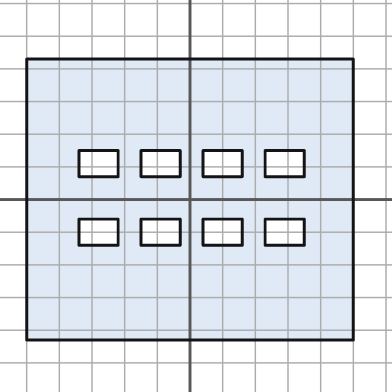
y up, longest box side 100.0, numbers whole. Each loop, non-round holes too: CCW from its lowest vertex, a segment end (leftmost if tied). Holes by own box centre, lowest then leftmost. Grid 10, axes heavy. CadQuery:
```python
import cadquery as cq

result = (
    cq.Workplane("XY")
    .moveTo(-50.0, -43.0)
    .lineTo(50.0, -43.0)
    .lineTo(50.0, 43.0)
    .lineTo(-50.0, 43.0)
    .close()
    .moveTo(-34.0, -14.0)
    .lineTo(-22.0, -14.0)
    .lineTo(-22.0, -6.0)
    .lineTo(-34.0, -6.0)
    .close()
    .moveTo(-15.0, -14.0)
    .lineTo(-3.0, -14.0)
    .lineTo(-3.0, -6.0)
    .lineTo(-15.0, -6.0)
    .close()
    .moveTo(4.0, -14.0)
    .lineTo(16.0, -14.0)
    .lineTo(16.0, -6.0)
    .lineTo(4.0, -6.0)
    .close()
    .moveTo(23.0, -14.0)
    .lineTo(35.0, -14.0)
    .lineTo(35.0, -6.0)
    .lineTo(23.0, -6.0)
    .close()
    .moveTo(-34.0, 7.0)
    .lineTo(-22.0, 7.0)
    .lineTo(-22.0, 15.0)
    .lineTo(-34.0, 15.0)
    .close()
    .moveTo(-15.0, 7.0)
    .lineTo(-3.0, 7.0)
    .lineTo(-3.0, 15.0)
    .lineTo(-15.0, 15.0)
    .close()
    .moveTo(4.0, 7.0)
    .lineTo(16.0, 7.0)
    .lineTo(16.0, 15.0)
    .lineTo(4.0, 15.0)
    .close()
    .moveTo(23.0, 7.0)
    .lineTo(35.0, 7.0)
    .lineTo(35.0, 15.0)
    .lineTo(23.0, 15.0)
    .close()
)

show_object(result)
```